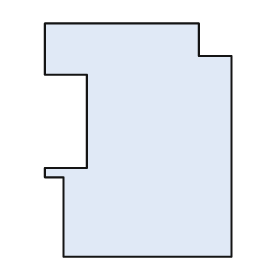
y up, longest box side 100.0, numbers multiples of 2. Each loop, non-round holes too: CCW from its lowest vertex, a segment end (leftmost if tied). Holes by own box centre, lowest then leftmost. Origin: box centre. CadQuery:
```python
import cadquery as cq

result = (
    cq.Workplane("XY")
    .moveTo(-32.0, -50.0)
    .lineTo(40.0, -50.0)
    .lineTo(40.0, 36.0)
    .lineTo(26.0, 36.0)
    .lineTo(26.0, 50.0)
    .lineTo(-40.0, 50.0)
    .lineTo(-40.0, 28.0)
    .lineTo(-22.0, 28.0)
    .lineTo(-22.0, -12.0)
    .lineTo(-40.0, -12.0)
    .lineTo(-40.0, -16.0)
    .lineTo(-32.0, -16.0)
    .close()
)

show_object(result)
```